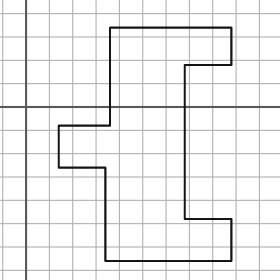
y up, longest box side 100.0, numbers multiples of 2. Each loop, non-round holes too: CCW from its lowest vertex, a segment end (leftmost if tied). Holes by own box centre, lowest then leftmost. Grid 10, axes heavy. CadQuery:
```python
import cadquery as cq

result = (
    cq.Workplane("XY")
    .moveTo(34.0, -66.0)
    .lineTo(88.0, -66.0)
    .lineTo(88.0, -48.0)
    .lineTo(68.0, -48.0)
    .lineTo(68.0, 18.0)
    .lineTo(88.0, 18.0)
    .lineTo(88.0, 34.0)
    .lineTo(36.0, 34.0)
    .lineTo(36.0, -8.0)
    .lineTo(14.0, -8.0)
    .lineTo(14.0, -26.0)
    .lineTo(34.0, -26.0)
    .close()
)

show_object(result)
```